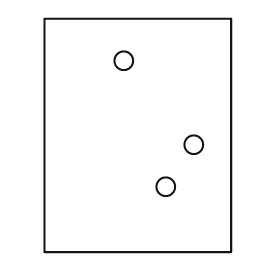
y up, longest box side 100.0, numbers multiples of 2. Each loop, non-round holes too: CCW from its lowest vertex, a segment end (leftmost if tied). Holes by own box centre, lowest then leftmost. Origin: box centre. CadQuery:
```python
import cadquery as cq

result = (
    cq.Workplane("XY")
    .moveTo(-40.0, -50.0)
    .lineTo(40.0, -50.0)
    .lineTo(40.0, 50.0)
    .lineTo(-40.0, 50.0)
    .close()
    .moveTo(12.0, -22.0)
    .circle(4.0)
    .moveTo(24.0, -4.0)
    .circle(4.0)
    .moveTo(-6.0, 32.0)
    .circle(4.0)
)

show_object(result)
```